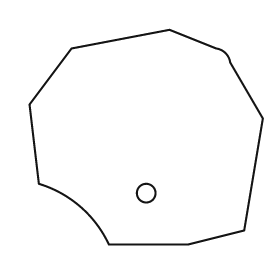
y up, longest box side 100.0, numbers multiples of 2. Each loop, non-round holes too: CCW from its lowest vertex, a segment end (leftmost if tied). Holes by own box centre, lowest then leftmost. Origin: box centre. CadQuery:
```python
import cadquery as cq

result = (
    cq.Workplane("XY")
    .moveTo(-16.0, -46.0)
    .lineTo(18.0, -46.0)
    .lineTo(42.0, -40.0)
    .lineTo(50.0, 8.0)
    .lineTo(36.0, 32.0)
    .threePointArc((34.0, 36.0), (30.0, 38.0))
    .lineTo(10.0, 46.0)
    .lineTo(-32.0, 38.0)
    .lineTo(-50.0, 14.0)
    .lineTo(-46.0, -20.0)
    .threePointArc((-28.0, -30.0), (-16.0, -46.0))
    .close()
    .moveTo(0.0, -24.0)
    .circle(4.0)
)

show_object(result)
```